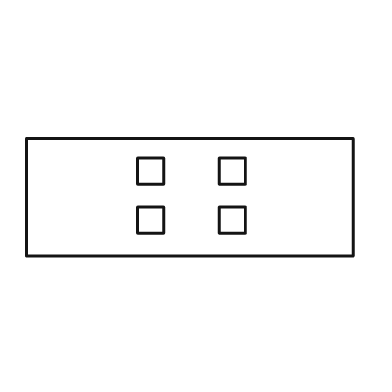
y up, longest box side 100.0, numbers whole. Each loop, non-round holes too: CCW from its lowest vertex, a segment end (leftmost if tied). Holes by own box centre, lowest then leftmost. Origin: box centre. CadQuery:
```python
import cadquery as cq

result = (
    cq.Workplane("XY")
    .moveTo(-50.0, -18.0)
    .lineTo(50.0, -18.0)
    .lineTo(50.0, 18.0)
    .lineTo(-50.0, 18.0)
    .close()
    .moveTo(-16.0, -11.0)
    .lineTo(-8.0, -11.0)
    .lineTo(-8.0, -3.0)
    .lineTo(-16.0, -3.0)
    .close()
    .moveTo(9.0, -11.0)
    .lineTo(17.0, -11.0)
    .lineTo(17.0, -3.0)
    .lineTo(9.0, -3.0)
    .close()
    .moveTo(-16.0, 4.0)
    .lineTo(-8.0, 4.0)
    .lineTo(-8.0, 12.0)
    .lineTo(-16.0, 12.0)
    .close()
    .moveTo(9.0, 4.0)
    .lineTo(17.0, 4.0)
    .lineTo(17.0, 12.0)
    .lineTo(9.0, 12.0)
    .close()
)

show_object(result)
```